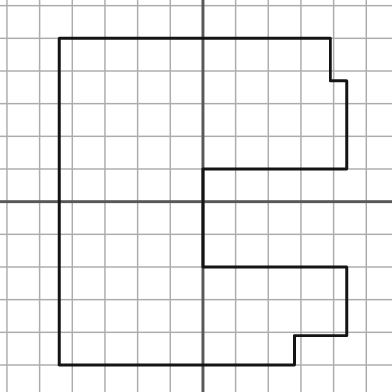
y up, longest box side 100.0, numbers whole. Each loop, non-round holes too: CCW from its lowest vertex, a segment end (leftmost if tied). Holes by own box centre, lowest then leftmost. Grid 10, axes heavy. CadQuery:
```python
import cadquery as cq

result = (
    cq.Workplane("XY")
    .moveTo(-44.0, -50.0)
    .lineTo(28.0, -50.0)
    .lineTo(28.0, -41.0)
    .lineTo(44.0, -41.0)
    .lineTo(44.0, -20.0)
    .lineTo(0.0, -20.0)
    .lineTo(0.0, 10.0)
    .lineTo(44.0, 10.0)
    .lineTo(44.0, 37.0)
    .lineTo(39.0, 37.0)
    .lineTo(39.0, 50.0)
    .lineTo(-44.0, 50.0)
    .close()
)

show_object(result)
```